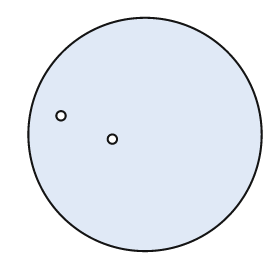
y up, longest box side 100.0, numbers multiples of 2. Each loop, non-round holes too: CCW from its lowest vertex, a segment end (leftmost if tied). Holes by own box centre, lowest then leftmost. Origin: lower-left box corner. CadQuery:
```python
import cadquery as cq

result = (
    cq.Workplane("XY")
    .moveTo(50.0, 50.0)
    .circle(50.0)
    .moveTo(36.0, 48.0)
    .circle(2.0)
    .moveTo(14.0, 58.0)
    .circle(2.0)
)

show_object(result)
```